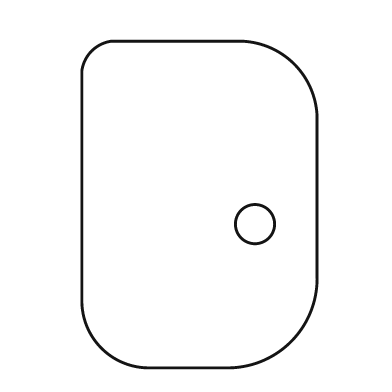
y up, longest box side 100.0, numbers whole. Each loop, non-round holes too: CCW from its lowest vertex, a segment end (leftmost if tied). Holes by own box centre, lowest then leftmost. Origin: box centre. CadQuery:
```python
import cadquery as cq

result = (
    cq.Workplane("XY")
    .moveTo(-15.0, -50.0)
    .lineTo(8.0, -50.0)
    .threePointArc((28.0, -42.0), (36.0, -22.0))
    .lineTo(36.0, 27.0)
    .threePointArc((29.0, 43.0), (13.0, 50.0))
    .lineTo(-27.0, 50.0)
    .threePointArc((-33.0, 47.0), (-36.0, 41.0))
    .lineTo(-36.0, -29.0)
    .threePointArc((-30.0, -44.0), (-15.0, -50.0))
    .close()
    .moveTo(17.0, -6.0)
    .circle(6.0)
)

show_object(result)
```